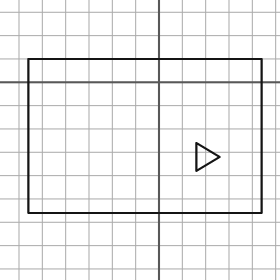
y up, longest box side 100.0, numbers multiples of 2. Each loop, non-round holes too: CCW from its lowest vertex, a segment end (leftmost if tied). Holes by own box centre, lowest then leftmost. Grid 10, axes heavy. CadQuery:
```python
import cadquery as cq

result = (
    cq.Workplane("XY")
    .moveTo(-56.0, -56.0)
    .lineTo(44.0, -56.0)
    .lineTo(44.0, 10.0)
    .lineTo(-56.0, 10.0)
    .close()
    .moveTo(16.0, -38.0)
    .lineTo(26.0, -32.0)
    .lineTo(16.0, -26.0)
    .close()
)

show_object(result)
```